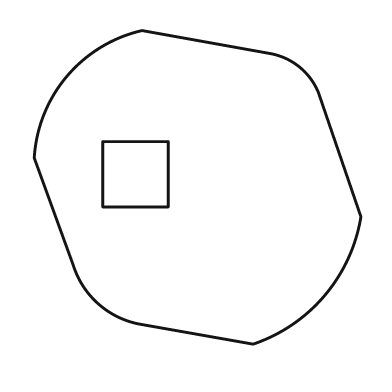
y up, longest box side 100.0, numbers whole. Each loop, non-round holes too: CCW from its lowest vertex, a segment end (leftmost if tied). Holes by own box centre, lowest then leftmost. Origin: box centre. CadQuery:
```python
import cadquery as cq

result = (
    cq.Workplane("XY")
    .moveTo(17.0, -48.0)
    .threePointArc((39.0, -33.0), (50.0, -9.0))
    .lineTo(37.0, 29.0)
    .threePointArc((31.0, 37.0), (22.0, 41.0))
    .lineTo(-17.0, 48.0)
    .threePointArc((-40.0, 34.0), (-50.0, 9.0))
    .lineTo(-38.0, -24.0)
    .threePointArc((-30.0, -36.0), (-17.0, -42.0))
    .close()
    .moveTo(-29.0, -6.0)
    .lineTo(-9.0, -6.0)
    .lineTo(-9.0, 14.0)
    .lineTo(-29.0, 14.0)
    .close()
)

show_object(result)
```